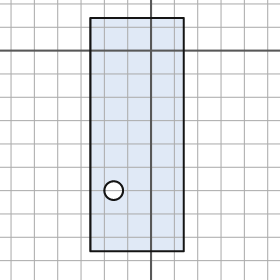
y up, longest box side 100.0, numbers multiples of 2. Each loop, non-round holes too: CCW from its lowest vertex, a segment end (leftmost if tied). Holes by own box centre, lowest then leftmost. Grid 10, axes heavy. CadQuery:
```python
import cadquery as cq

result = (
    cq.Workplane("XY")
    .moveTo(-26.0, -86.0)
    .lineTo(14.0, -86.0)
    .lineTo(14.0, 14.0)
    .lineTo(-26.0, 14.0)
    .close()
    .moveTo(-16.0, -60.0)
    .circle(4.0)
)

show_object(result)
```